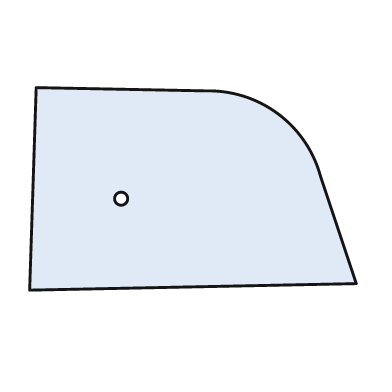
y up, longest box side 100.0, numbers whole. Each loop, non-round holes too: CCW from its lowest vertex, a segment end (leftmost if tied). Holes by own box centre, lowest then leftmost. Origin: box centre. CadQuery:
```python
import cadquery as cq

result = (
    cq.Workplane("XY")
    .moveTo(-50.0, -31.0)
    .lineTo(50.0, -29.0)
    .lineTo(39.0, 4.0)
    .threePointArc((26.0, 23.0), (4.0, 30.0))
    .lineTo(-48.0, 31.0)
    .close()
    .moveTo(-22.0, -3.0)
    .circle(2.0)
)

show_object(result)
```